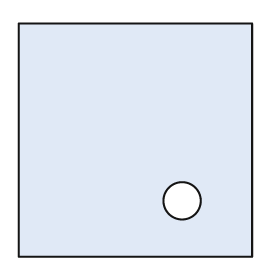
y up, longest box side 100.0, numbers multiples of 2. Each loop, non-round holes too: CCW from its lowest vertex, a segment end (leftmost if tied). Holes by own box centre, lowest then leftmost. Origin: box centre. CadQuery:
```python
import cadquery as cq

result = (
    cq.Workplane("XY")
    .moveTo(-50.0, -50.0)
    .lineTo(50.0, -50.0)
    .lineTo(50.0, 50.0)
    .lineTo(-50.0, 50.0)
    .close()
    .moveTo(20.0, -26.0)
    .circle(8.0)
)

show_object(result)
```